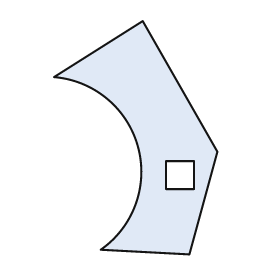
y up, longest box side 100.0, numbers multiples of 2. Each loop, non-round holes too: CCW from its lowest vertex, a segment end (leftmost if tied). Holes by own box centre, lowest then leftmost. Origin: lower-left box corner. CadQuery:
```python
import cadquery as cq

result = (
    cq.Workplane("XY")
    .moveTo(58.0, 0.0)
    .lineTo(70.0, 44.0)
    .lineTo(38.0, 100.0)
    .lineTo(0.0, 76.0)
    .threePointArc((36.0, 46.0), (20.0, 2.0))
    .close()
    .moveTo(48.0, 28.0)
    .lineTo(60.0, 28.0)
    .lineTo(60.0, 40.0)
    .lineTo(48.0, 40.0)
    .close()
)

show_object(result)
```